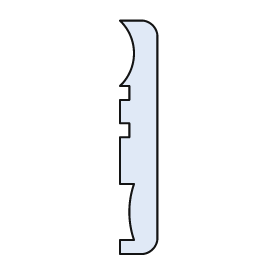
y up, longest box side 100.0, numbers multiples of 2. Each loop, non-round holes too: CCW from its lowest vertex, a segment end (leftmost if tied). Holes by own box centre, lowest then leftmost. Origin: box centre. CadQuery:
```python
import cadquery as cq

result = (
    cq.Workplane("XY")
    .moveTo(-8.0, -50.0)
    .lineTo(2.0, -50.0)
    .threePointArc((6.0, -48.0), (8.0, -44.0))
    .lineTo(8.0, 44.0)
    .threePointArc((6.0, 48.0), (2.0, 50.0))
    .lineTo(-8.0, 50.0)
    .threePointArc((-2.0, 36.0), (-8.0, 22.0))
    .lineTo(-4.0, 22.0)
    .lineTo(-4.0, 16.0)
    .lineTo(-8.0, 16.0)
    .lineTo(-8.0, 6.0)
    .lineTo(-4.0, 6.0)
    .lineTo(-4.0, 0.0)
    .lineTo(-8.0, 0.0)
    .lineTo(-8.0, -20.0)
    .lineTo(-2.0, -20.0)
    .threePointArc((-4.0, -32.0), (-2.0, -44.0))
    .lineTo(-8.0, -44.0)
    .close()
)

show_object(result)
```